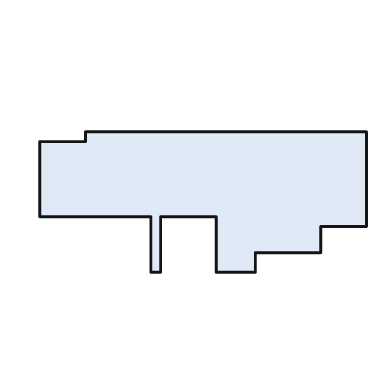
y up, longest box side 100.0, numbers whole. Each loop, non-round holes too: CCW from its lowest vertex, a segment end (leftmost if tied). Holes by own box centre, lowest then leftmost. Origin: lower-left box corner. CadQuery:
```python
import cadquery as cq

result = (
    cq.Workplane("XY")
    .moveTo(34.0, 0.0)
    .lineTo(37.0, 0.0)
    .lineTo(37.0, 17.0)
    .lineTo(54.0, 17.0)
    .lineTo(54.0, 0.0)
    .lineTo(66.0, 0.0)
    .lineTo(66.0, 6.0)
    .lineTo(86.0, 6.0)
    .lineTo(86.0, 14.0)
    .lineTo(100.0, 14.0)
    .lineTo(100.0, 43.0)
    .lineTo(14.0, 43.0)
    .lineTo(14.0, 40.0)
    .lineTo(0.0, 40.0)
    .lineTo(0.0, 17.0)
    .lineTo(34.0, 17.0)
    .close()
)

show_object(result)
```